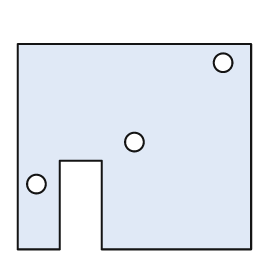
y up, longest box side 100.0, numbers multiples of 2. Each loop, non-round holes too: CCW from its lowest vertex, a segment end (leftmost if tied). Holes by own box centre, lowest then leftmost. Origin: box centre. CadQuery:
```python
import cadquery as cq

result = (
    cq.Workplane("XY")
    .moveTo(-50.0, -44.0)
    .lineTo(-32.0, -44.0)
    .lineTo(-32.0, -6.0)
    .lineTo(-14.0, -6.0)
    .lineTo(-14.0, -44.0)
    .lineTo(50.0, -44.0)
    .lineTo(50.0, 44.0)
    .lineTo(-50.0, 44.0)
    .close()
    .moveTo(-42.0, -16.0)
    .circle(4.0)
    .moveTo(0.0, 2.0)
    .circle(4.0)
    .moveTo(38.0, 36.0)
    .circle(4.0)
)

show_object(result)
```